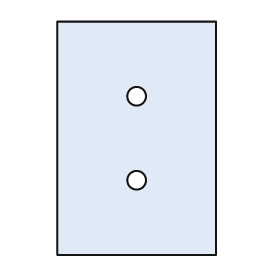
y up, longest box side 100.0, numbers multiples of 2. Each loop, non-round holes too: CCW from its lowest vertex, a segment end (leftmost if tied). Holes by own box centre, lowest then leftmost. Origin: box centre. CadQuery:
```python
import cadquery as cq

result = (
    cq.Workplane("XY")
    .moveTo(-34.0, -50.0)
    .lineTo(34.0, -50.0)
    .lineTo(34.0, 50.0)
    .lineTo(-34.0, 50.0)
    .close()
    .moveTo(0.0, -18.0)
    .circle(4.0)
    .moveTo(0.0, 18.0)
    .circle(4.0)
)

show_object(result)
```